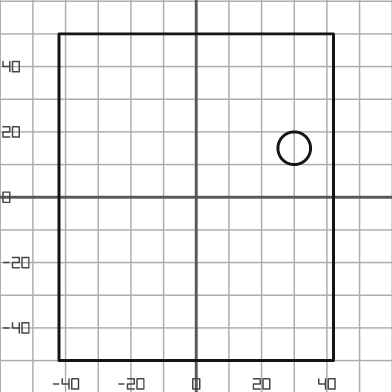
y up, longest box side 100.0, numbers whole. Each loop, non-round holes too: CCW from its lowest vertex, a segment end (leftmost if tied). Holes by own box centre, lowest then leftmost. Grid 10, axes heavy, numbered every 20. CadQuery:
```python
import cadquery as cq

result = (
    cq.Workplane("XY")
    .moveTo(-42.0, -50.0)
    .lineTo(42.0, -50.0)
    .lineTo(42.0, 50.0)
    .lineTo(-42.0, 50.0)
    .close()
    .moveTo(30.0, 15.0)
    .circle(5.0)
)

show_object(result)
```